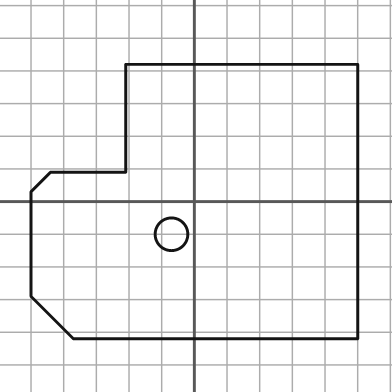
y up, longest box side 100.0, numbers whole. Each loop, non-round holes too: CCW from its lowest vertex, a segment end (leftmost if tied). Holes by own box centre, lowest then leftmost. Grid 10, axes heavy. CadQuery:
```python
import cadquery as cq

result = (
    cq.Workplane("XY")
    .moveTo(-37.0, -42.0)
    .lineTo(50.0, -42.0)
    .lineTo(50.0, 42.0)
    .lineTo(-21.0, 42.0)
    .lineTo(-21.0, 9.0)
    .lineTo(-44.0, 9.0)
    .lineTo(-50.0, 3.0)
    .lineTo(-50.0, -29.0)
    .close()
    .moveTo(-7.0, -10.0)
    .circle(5.0)
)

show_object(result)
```